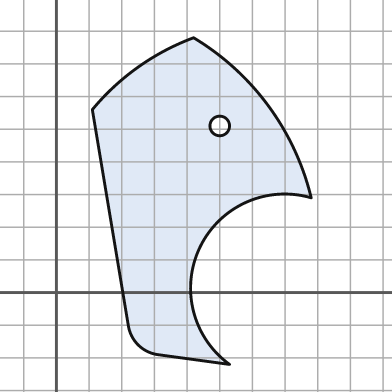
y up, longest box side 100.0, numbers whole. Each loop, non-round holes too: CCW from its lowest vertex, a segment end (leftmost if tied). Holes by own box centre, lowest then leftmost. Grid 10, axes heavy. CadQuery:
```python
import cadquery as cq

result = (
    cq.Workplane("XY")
    .moveTo(53.0, -22.0)
    .threePointArc((44.0, 14.0), (78.0, 29.0))
    .threePointArc((65.0, 57.0), (42.0, 78.0))
    .threePointArc((25.0, 69.0), (11.0, 56.0))
    .lineTo(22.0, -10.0)
    .threePointArc((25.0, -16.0), (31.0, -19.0))
    .close()
    .moveTo(50.0, 51.0)
    .circle(3.0)
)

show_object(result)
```